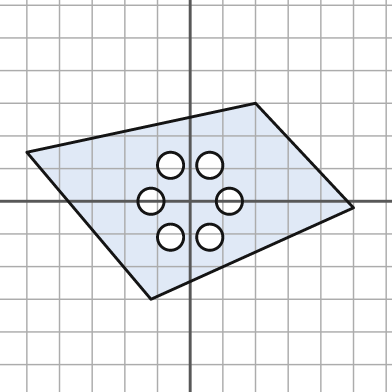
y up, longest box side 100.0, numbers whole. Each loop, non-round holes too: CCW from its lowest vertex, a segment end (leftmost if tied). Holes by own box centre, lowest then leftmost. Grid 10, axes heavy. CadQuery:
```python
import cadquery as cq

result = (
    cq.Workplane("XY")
    .moveTo(-12.0, -30.0)
    .lineTo(50.0, -2.0)
    .lineTo(20.0, 30.0)
    .lineTo(-50.0, 15.0)
    .close()
    .moveTo(-6.0, -11.0)
    .circle(4.0)
    .moveTo(6.0, -11.0)
    .circle(4.0)
    .moveTo(-12.0, 0.0)
    .circle(4.0)
    .moveTo(12.0, 0.0)
    .circle(4.0)
    .moveTo(-6.0, 11.0)
    .circle(4.0)
    .moveTo(6.0, 11.0)
    .circle(4.0)
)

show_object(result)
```